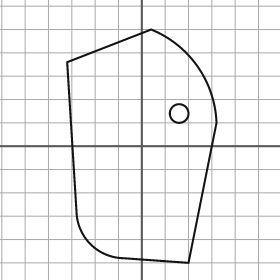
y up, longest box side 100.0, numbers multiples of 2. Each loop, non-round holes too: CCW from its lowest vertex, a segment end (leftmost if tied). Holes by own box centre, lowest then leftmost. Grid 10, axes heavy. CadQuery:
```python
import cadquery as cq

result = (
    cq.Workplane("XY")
    .moveTo(20.0, -50.0)
    .lineTo(32.0, 10.0)
    .threePointArc((24.0, 34.0), (4.0, 50.0))
    .lineTo(-32.0, 36.0)
    .lineTo(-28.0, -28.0)
    .threePointArc((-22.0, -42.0), (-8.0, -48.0))
    .close()
    .moveTo(16.0, 14.0)
    .circle(4.0)
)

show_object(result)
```